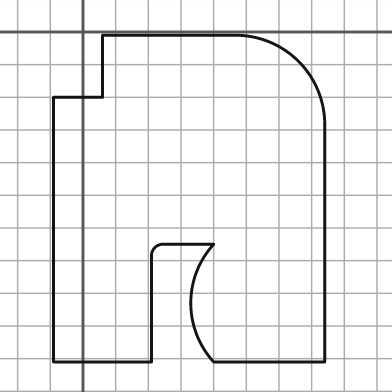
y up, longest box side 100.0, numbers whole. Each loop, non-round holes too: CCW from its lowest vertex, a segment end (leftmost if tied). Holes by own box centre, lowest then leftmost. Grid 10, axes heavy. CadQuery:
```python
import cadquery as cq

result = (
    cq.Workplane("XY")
    .moveTo(-9.0, -101.0)
    .lineTo(21.0, -101.0)
    .lineTo(21.0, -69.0)
    .threePointArc((22.0, -66.0), (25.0, -65.0))
    .lineTo(40.0, -65.0)
    .threePointArc((33.0, -83.0), (40.0, -101.0))
    .lineTo(74.0, -101.0)
    .lineTo(74.0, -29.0)
    .threePointArc((66.0, -9.0), (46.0, -1.0))
    .lineTo(6.0, -1.0)
    .lineTo(6.0, -20.0)
    .lineTo(-9.0, -20.0)
    .close()
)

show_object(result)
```